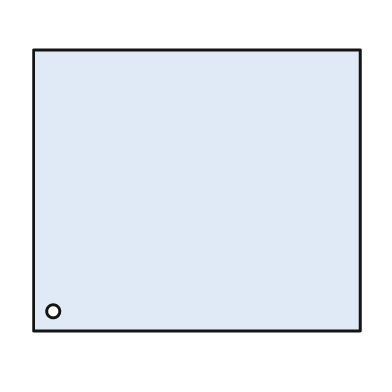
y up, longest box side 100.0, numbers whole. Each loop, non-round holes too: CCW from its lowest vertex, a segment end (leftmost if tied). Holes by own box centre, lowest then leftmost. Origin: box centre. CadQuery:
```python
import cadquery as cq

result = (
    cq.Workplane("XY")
    .moveTo(-50.0, -43.0)
    .lineTo(50.0, -43.0)
    .lineTo(50.0, 43.0)
    .lineTo(-50.0, 43.0)
    .close()
    .moveTo(-44.0, -37.0)
    .circle(2.0)
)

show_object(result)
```